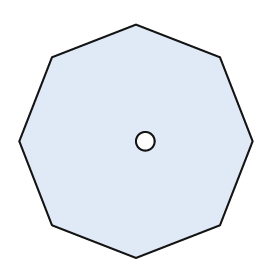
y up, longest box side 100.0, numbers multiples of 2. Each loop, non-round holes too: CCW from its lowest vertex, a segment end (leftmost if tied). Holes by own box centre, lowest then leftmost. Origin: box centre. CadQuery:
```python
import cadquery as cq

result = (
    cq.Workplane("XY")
    .moveTo(0.0, -50.0)
    .lineTo(36.0, -36.0)
    .lineTo(50.0, 0.0)
    .lineTo(36.0, 36.0)
    .lineTo(0.0, 50.0)
    .lineTo(-36.0, 36.0)
    .lineTo(-50.0, 0.0)
    .lineTo(-36.0, -36.0)
    .close()
    .moveTo(4.0, 0.0)
    .circle(4.0)
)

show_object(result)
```